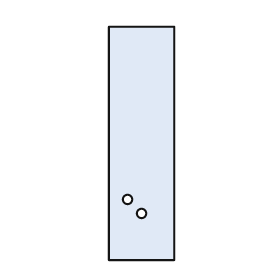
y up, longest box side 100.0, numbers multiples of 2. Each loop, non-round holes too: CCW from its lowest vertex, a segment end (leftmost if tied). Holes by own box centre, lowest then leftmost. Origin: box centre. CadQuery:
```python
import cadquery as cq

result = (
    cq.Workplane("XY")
    .moveTo(-14.0, -50.0)
    .lineTo(14.0, -50.0)
    .lineTo(14.0, 50.0)
    .lineTo(-14.0, 50.0)
    .close()
    .moveTo(0.0, -30.0)
    .circle(2.0)
    .moveTo(-6.0, -24.0)
    .circle(2.0)
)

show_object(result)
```